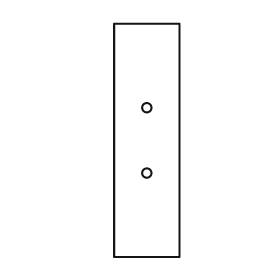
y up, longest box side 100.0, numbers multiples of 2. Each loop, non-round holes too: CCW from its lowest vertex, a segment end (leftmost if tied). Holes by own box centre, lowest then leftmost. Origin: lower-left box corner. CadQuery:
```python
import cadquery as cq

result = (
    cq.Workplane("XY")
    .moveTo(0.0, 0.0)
    .lineTo(28.0, 0.0)
    .lineTo(28.0, 100.0)
    .lineTo(0.0, 100.0)
    .close()
    .moveTo(14.0, 36.0)
    .circle(2.0)
    .moveTo(14.0, 64.0)
    .circle(2.0)
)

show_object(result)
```